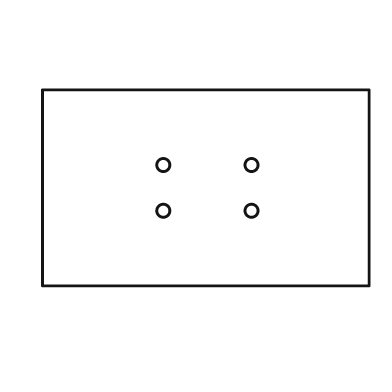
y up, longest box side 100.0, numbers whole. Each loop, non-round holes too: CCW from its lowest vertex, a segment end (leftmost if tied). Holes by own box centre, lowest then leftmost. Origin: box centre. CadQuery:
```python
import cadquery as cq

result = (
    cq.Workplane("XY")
    .moveTo(-50.0, -30.0)
    .lineTo(50.0, -30.0)
    .lineTo(50.0, 30.0)
    .lineTo(-50.0, 30.0)
    .close()
    .moveTo(-13.0, -7.0)
    .circle(2.0)
    .moveTo(14.0, -7.0)
    .circle(2.0)
    .moveTo(-13.0, 7.0)
    .circle(2.0)
    .moveTo(14.0, 7.0)
    .circle(2.0)
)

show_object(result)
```